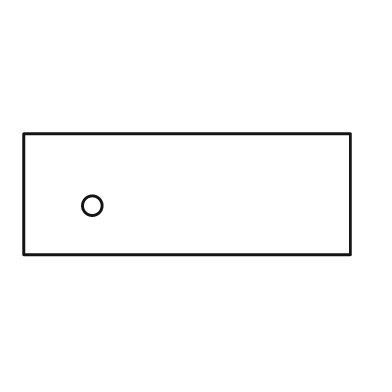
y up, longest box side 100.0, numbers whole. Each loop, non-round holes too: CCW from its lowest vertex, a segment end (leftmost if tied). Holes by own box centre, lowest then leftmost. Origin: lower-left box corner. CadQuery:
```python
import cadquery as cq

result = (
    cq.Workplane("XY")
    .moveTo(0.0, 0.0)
    .lineTo(100.0, 0.0)
    .lineTo(100.0, 37.0)
    .lineTo(0.0, 37.0)
    .close()
    .moveTo(21.0, 15.0)
    .circle(3.0)
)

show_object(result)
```